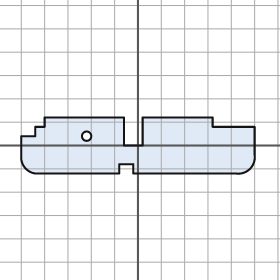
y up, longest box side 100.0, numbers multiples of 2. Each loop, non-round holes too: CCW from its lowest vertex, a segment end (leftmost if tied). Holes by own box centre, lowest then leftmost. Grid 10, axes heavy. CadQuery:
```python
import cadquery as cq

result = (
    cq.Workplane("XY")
    .moveTo(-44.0, -12.0)
    .lineTo(-8.0, -12.0)
    .lineTo(-8.0, -8.0)
    .lineTo(-2.0, -8.0)
    .lineTo(-2.0, -12.0)
    .lineTo(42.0, -12.0)
    .threePointArc((48.0, -10.0), (50.0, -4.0))
    .lineTo(50.0, 8.0)
    .lineTo(32.0, 8.0)
    .lineTo(32.0, 12.0)
    .lineTo(2.0, 12.0)
    .lineTo(2.0, 0.0)
    .lineTo(-6.0, 0.0)
    .lineTo(-6.0, 12.0)
    .lineTo(-40.0, 12.0)
    .lineTo(-40.0, 8.0)
    .lineTo(-44.0, 8.0)
    .lineTo(-44.0, 4.0)
    .lineTo(-50.0, 4.0)
    .lineTo(-50.0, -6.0)
    .threePointArc((-48.0, -10.0), (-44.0, -12.0))
    .close()
    .moveTo(-22.0, 4.0)
    .circle(2.0)
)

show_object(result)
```